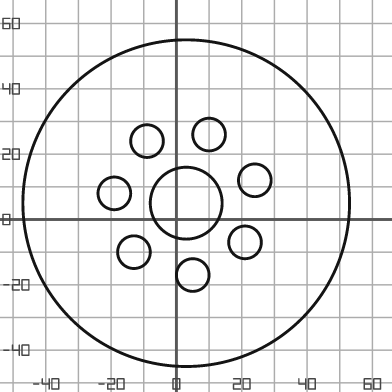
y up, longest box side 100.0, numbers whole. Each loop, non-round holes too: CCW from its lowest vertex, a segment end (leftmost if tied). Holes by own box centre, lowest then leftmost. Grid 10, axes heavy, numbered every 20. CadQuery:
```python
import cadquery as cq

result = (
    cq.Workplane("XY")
    .moveTo(3.0, 5.0)
    .circle(50.0)
    .moveTo(5.0, -17.0)
    .circle(5.0)
    .moveTo(-13.0, -10.0)
    .circle(5.0)
    .moveTo(21.0, -7.0)
    .circle(5.0)
    .moveTo(3.0, 5.0)
    .circle(11.0)
    .moveTo(-19.0, 8.0)
    .circle(5.0)
    .moveTo(24.0, 12.0)
    .circle(5.0)
    .moveTo(-9.0, 24.0)
    .circle(5.0)
    .moveTo(10.0, 26.0)
    .circle(5.0)
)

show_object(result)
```